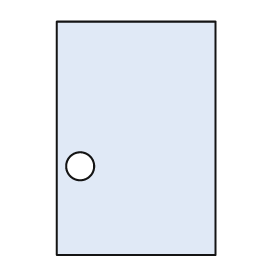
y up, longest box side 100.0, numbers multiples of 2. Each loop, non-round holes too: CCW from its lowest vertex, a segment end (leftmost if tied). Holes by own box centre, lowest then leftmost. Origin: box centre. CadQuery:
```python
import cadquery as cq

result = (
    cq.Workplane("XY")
    .moveTo(-34.0, -50.0)
    .lineTo(34.0, -50.0)
    .lineTo(34.0, 50.0)
    .lineTo(-34.0, 50.0)
    .close()
    .moveTo(-24.0, -12.0)
    .circle(6.0)
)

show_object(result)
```